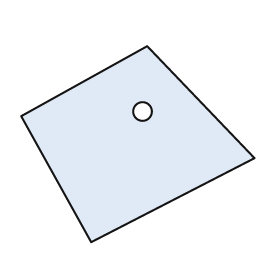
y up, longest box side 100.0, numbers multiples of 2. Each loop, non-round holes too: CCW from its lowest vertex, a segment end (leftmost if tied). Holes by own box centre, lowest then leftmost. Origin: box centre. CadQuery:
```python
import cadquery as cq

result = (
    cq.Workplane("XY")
    .moveTo(-20.0, -42.0)
    .lineTo(50.0, -6.0)
    .lineTo(4.0, 42.0)
    .lineTo(-50.0, 12.0)
    .close()
    .moveTo(2.0, 14.0)
    .circle(4.0)
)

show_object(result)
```